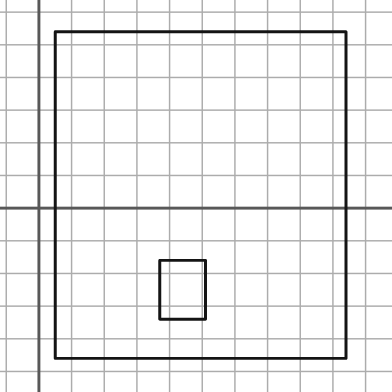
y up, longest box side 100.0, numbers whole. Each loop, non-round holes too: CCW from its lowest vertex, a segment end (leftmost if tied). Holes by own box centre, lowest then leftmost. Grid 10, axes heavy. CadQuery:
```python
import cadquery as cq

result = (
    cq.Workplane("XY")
    .moveTo(5.0, -46.0)
    .lineTo(94.0, -46.0)
    .lineTo(94.0, 54.0)
    .lineTo(5.0, 54.0)
    .close()
    .moveTo(37.0, -34.0)
    .lineTo(51.0, -34.0)
    .lineTo(51.0, -16.0)
    .lineTo(37.0, -16.0)
    .close()
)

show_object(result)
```